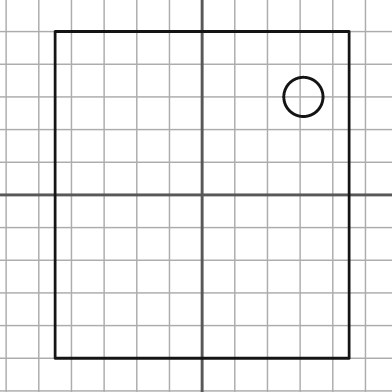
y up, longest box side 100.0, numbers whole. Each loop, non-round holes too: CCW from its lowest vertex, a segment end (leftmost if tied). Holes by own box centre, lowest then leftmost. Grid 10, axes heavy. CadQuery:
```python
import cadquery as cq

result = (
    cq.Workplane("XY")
    .moveTo(-45.0, -50.0)
    .lineTo(45.0, -50.0)
    .lineTo(45.0, 50.0)
    .lineTo(-45.0, 50.0)
    .close()
    .moveTo(31.0, 30.0)
    .circle(6.0)
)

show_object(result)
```